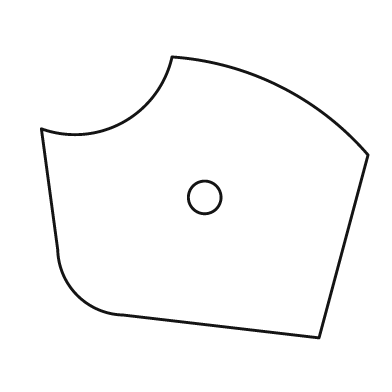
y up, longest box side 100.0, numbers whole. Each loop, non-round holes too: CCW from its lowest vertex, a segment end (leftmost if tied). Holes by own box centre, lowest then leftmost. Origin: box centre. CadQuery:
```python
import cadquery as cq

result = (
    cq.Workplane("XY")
    .moveTo(35.0, -43.0)
    .lineTo(50.0, 13.0)
    .threePointArc((23.0, 34.0), (-10.0, 43.0))
    .threePointArc((-25.0, 23.0), (-50.0, 21.0))
    .lineTo(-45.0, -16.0)
    .threePointArc((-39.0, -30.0), (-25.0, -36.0))
    .close()
    .moveTo(0.0, 0.0)
    .circle(5.0)
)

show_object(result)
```